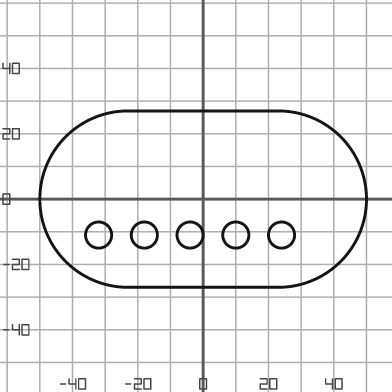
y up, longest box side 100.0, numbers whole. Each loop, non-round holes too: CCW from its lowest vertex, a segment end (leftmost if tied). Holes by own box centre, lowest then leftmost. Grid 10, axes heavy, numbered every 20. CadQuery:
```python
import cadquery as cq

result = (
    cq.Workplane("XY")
    .moveTo(-23.0, -27.0)
    .lineTo(23.0, -27.0)
    .threePointArc((50.0, 0.0), (23.0, 27.0))
    .lineTo(-23.0, 27.0)
    .threePointArc((-50.0, 0.0), (-23.0, -27.0))
    .close()
    .moveTo(-32.0, -11.0)
    .circle(4.0)
    .moveTo(-18.0, -11.0)
    .circle(4.0)
    .moveTo(-4.0, -11.0)
    .circle(4.0)
    .moveTo(10.0, -11.0)
    .circle(4.0)
    .moveTo(24.0, -11.0)
    .circle(4.0)
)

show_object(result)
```